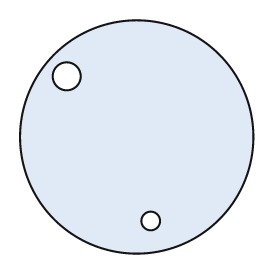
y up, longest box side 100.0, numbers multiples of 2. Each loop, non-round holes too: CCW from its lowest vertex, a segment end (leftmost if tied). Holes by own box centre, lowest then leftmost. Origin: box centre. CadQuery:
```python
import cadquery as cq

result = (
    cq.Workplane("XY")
    .moveTo(0.0, 0.0)
    .circle(50.0)
    .moveTo(6.0, -36.0)
    .circle(4.0)
    .moveTo(-30.0, 26.0)
    .circle(6.0)
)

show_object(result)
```